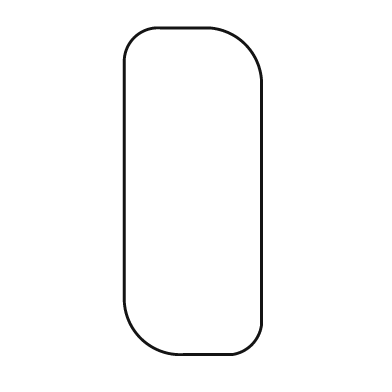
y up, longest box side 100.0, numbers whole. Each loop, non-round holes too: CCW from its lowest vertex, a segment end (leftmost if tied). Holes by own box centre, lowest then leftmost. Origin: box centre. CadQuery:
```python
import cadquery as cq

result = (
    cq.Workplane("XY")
    .moveTo(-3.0, -50.0)
    .lineTo(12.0, -50.0)
    .threePointArc((18.0, -47.0), (21.0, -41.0))
    .lineTo(21.0, 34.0)
    .threePointArc((16.0, 45.0), (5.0, 50.0))
    .lineTo(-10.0, 50.0)
    .threePointArc((-18.0, 47.0), (-21.0, 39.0))
    .lineTo(-21.0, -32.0)
    .threePointArc((-16.0, -45.0), (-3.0, -50.0))
    .close()
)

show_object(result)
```